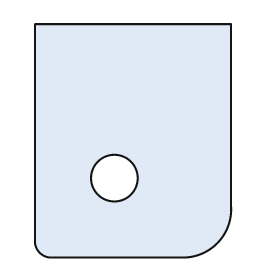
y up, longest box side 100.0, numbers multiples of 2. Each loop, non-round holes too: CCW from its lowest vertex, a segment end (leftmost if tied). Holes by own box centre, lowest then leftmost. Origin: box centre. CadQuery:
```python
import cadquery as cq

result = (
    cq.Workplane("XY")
    .moveTo(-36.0, -50.0)
    .lineTo(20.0, -50.0)
    .threePointArc((36.0, -44.0), (42.0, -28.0))
    .lineTo(42.0, 50.0)
    .lineTo(-42.0, 50.0)
    .lineTo(-42.0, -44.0)
    .threePointArc((-40.0, -48.0), (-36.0, -50.0))
    .close()
    .moveTo(-8.0, -16.0)
    .circle(10.0)
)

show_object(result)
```